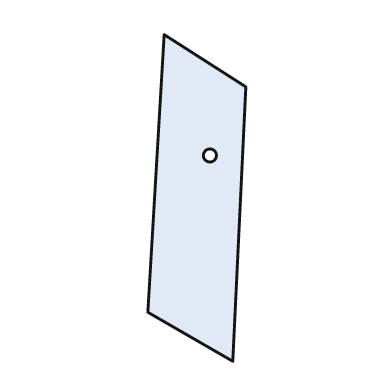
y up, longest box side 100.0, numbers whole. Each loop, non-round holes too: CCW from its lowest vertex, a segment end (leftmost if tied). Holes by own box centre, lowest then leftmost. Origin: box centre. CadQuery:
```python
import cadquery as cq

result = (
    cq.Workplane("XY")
    .moveTo(11.0, -50.0)
    .lineTo(15.0, 34.0)
    .lineTo(-10.0, 50.0)
    .lineTo(-15.0, -35.0)
    .close()
    .moveTo(4.0, 13.0)
    .circle(2.0)
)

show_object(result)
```